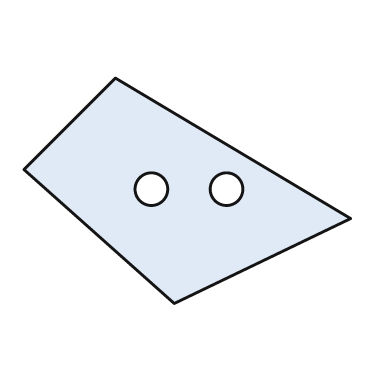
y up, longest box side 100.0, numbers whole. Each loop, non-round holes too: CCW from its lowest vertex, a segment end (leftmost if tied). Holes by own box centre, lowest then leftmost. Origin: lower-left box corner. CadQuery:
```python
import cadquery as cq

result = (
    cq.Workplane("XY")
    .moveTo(46.0, 0.0)
    .lineTo(100.0, 26.0)
    .lineTo(28.0, 69.0)
    .lineTo(0.0, 41.0)
    .close()
    .moveTo(39.0, 35.0)
    .circle(5.0)
    .moveTo(62.0, 35.0)
    .circle(5.0)
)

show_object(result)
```